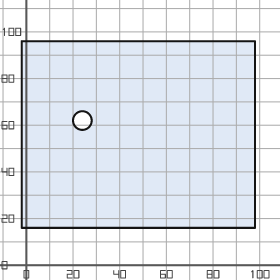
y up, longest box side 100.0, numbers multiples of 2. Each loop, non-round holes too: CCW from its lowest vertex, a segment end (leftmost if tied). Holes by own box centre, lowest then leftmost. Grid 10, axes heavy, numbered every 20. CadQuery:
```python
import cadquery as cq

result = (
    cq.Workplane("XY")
    .moveTo(-2.0, 16.0)
    .lineTo(98.0, 16.0)
    .lineTo(98.0, 96.0)
    .lineTo(-2.0, 96.0)
    .close()
    .moveTo(24.0, 62.0)
    .circle(4.0)
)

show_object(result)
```